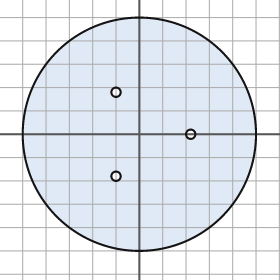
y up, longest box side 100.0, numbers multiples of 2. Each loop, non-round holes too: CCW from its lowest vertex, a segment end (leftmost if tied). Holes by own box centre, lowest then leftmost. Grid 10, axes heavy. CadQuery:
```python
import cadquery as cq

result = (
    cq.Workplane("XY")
    .moveTo(0.0, 0.0)
    .circle(50.0)
    .moveTo(-10.0, -18.0)
    .circle(2.0)
    .moveTo(22.0, 0.0)
    .circle(2.0)
    .moveTo(-10.0, 18.0)
    .circle(2.0)
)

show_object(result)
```